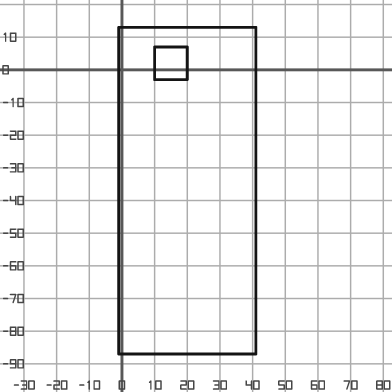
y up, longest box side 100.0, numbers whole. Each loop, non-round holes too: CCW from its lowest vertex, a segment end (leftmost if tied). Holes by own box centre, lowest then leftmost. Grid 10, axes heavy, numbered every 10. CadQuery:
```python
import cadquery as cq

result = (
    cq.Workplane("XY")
    .moveTo(-1.0, -87.0)
    .lineTo(41.0, -87.0)
    .lineTo(41.0, 13.0)
    .lineTo(-1.0, 13.0)
    .close()
    .moveTo(10.0, -3.0)
    .lineTo(20.0, -3.0)
    .lineTo(20.0, 7.0)
    .lineTo(10.0, 7.0)
    .close()
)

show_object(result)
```